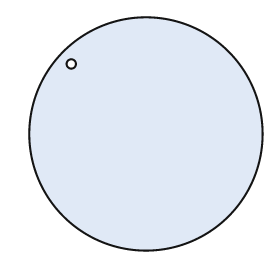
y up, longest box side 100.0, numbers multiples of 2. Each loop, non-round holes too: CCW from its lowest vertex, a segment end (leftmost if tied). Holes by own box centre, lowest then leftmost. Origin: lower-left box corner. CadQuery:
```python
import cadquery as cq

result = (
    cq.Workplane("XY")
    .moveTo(50.0, 50.0)
    .circle(50.0)
    .moveTo(18.0, 80.0)
    .circle(2.0)
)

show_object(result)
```